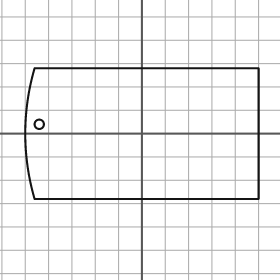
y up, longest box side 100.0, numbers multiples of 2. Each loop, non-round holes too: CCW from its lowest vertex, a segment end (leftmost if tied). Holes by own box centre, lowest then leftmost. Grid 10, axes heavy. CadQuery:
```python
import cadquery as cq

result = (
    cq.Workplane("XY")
    .moveTo(-46.0, -28.0)
    .lineTo(50.0, -28.0)
    .lineTo(50.0, 28.0)
    .lineTo(-46.0, 28.0)
    .threePointArc((-50.0, 0.0), (-46.0, -28.0))
    .close()
    .moveTo(-44.0, 4.0)
    .circle(2.0)
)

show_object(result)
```